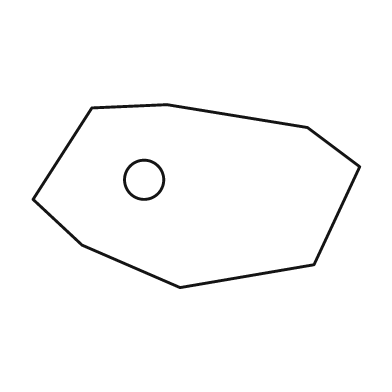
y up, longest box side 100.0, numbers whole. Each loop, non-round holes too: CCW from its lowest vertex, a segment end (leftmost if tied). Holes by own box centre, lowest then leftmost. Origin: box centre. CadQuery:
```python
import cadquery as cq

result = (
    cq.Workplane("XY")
    .moveTo(-5.0, -28.0)
    .lineTo(36.0, -21.0)
    .lineTo(50.0, 9.0)
    .lineTo(34.0, 21.0)
    .lineTo(-9.0, 28.0)
    .lineTo(-32.0, 27.0)
    .lineTo(-50.0, -1.0)
    .lineTo(-35.0, -15.0)
    .close()
    .moveTo(-16.0, 5.0)
    .circle(6.0)
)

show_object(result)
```